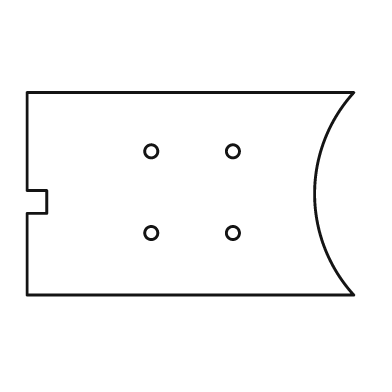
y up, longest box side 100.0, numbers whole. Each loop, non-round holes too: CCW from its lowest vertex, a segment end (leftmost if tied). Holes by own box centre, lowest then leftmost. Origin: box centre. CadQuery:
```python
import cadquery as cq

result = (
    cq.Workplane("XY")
    .moveTo(-50.0, -31.0)
    .lineTo(50.0, -31.0)
    .threePointArc((38.0, 0.0), (50.0, 31.0))
    .lineTo(-50.0, 31.0)
    .lineTo(-50.0, 1.0)
    .lineTo(-44.0, 1.0)
    .lineTo(-44.0, -6.0)
    .lineTo(-50.0, -6.0)
    .close()
    .moveTo(-12.0, -12.0)
    .circle(2.0)
    .moveTo(13.0, -12.0)
    .circle(2.0)
    .moveTo(-12.0, 13.0)
    .circle(2.0)
    .moveTo(13.0, 13.0)
    .circle(2.0)
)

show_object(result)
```